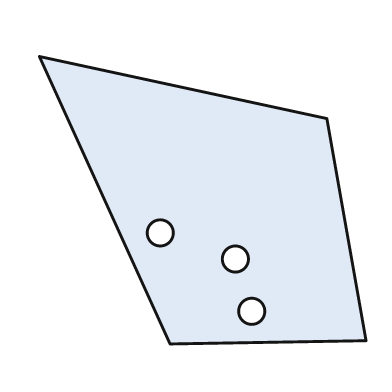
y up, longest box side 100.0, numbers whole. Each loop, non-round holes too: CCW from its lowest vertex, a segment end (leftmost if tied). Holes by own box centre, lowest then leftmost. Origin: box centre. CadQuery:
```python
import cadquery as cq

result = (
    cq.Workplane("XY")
    .moveTo(-10.0, -44.0)
    .lineTo(50.0, -43.0)
    .lineTo(38.0, 25.0)
    .lineTo(-50.0, 44.0)
    .close()
    .moveTo(15.0, -34.0)
    .circle(4.0)
    .moveTo(10.0, -18.0)
    .circle(4.0)
    .moveTo(-13.0, -10.0)
    .circle(4.0)
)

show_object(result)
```